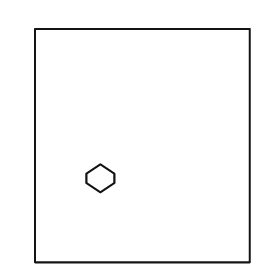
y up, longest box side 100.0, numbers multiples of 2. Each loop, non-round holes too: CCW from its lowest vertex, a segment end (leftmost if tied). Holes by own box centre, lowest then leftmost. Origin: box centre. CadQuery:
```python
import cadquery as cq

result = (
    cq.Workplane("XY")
    .moveTo(-46.0, -50.0)
    .lineTo(46.0, -50.0)
    .lineTo(46.0, 50.0)
    .lineTo(-46.0, 50.0)
    .close()
    .moveTo(-18.0, -20.0)
    .lineTo(-12.0, -16.0)
    .lineTo(-12.0, -12.0)
    .lineTo(-18.0, -8.0)
    .lineTo(-24.0, -12.0)
    .lineTo(-24.0, -16.0)
    .close()
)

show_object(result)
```